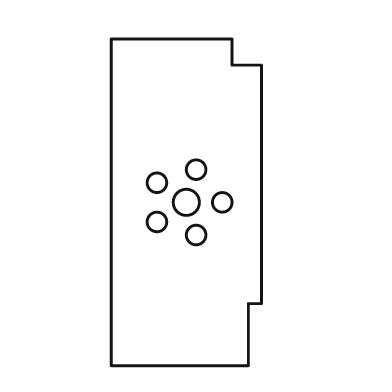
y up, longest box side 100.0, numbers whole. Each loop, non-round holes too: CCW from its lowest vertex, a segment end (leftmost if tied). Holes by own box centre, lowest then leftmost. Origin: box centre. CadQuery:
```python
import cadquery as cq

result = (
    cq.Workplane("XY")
    .moveTo(-23.0, -50.0)
    .lineTo(19.0, -50.0)
    .lineTo(19.0, -31.0)
    .lineTo(23.0, -31.0)
    .lineTo(23.0, 42.0)
    .lineTo(14.0, 42.0)
    .lineTo(14.0, 50.0)
    .lineTo(-23.0, 50.0)
    .close()
    .moveTo(3.0, -10.0)
    .circle(3.0)
    .moveTo(-9.0, -6.0)
    .circle(3.0)
    .moveTo(0.0, 0.0)
    .circle(4.0)
    .moveTo(11.0, 0.0)
    .circle(3.0)
    .moveTo(-9.0, 6.0)
    .circle(3.0)
    .moveTo(3.0, 10.0)
    .circle(3.0)
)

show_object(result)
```